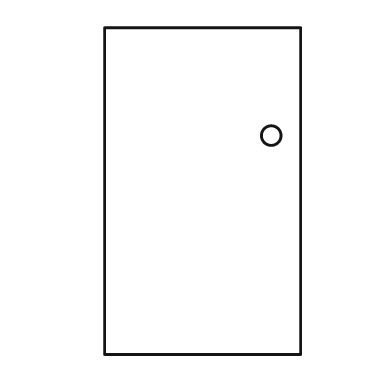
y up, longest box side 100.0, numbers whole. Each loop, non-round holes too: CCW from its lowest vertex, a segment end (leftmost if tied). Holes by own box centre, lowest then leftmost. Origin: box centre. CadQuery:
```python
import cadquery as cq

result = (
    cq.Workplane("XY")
    .moveTo(-30.0, -50.0)
    .lineTo(30.0, -50.0)
    .lineTo(30.0, 50.0)
    .lineTo(-30.0, 50.0)
    .close()
    .moveTo(21.0, 17.0)
    .circle(3.0)
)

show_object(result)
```